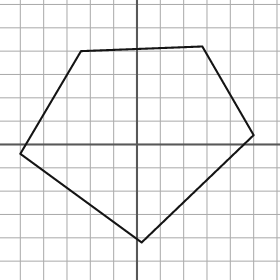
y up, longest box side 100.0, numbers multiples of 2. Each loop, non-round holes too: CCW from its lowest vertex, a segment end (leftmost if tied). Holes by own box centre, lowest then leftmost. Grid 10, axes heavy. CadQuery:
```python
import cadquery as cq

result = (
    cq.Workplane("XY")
    .moveTo(2.0, -42.0)
    .lineTo(50.0, 4.0)
    .lineTo(28.0, 42.0)
    .lineTo(-24.0, 40.0)
    .lineTo(-50.0, -4.0)
    .close()
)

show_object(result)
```